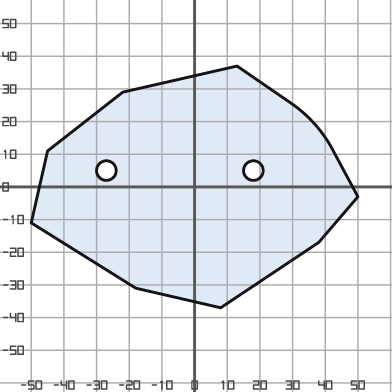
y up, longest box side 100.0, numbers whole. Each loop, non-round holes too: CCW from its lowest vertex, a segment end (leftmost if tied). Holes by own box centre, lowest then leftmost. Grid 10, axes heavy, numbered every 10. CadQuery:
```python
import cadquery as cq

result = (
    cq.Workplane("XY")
    .moveTo(8.0, -37.0)
    .lineTo(38.0, -17.0)
    .lineTo(50.0, -3.0)
    .lineTo(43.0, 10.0)
    .threePointArc((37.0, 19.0), (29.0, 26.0))
    .lineTo(13.0, 37.0)
    .lineTo(-22.0, 29.0)
    .lineTo(-45.0, 11.0)
    .lineTo(-50.0, -11.0)
    .lineTo(-18.0, -31.0)
    .close()
    .moveTo(-27.0, 5.0)
    .circle(3.0)
    .moveTo(18.0, 5.0)
    .circle(3.0)
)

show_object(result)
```